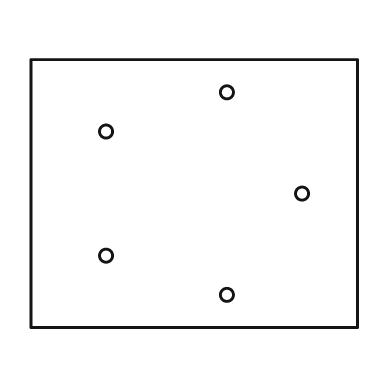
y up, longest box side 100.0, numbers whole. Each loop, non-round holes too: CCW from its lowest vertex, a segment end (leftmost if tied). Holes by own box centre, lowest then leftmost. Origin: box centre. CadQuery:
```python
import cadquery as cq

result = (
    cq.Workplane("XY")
    .moveTo(-50.0, -41.0)
    .lineTo(50.0, -41.0)
    .lineTo(50.0, 41.0)
    .lineTo(-50.0, 41.0)
    .close()
    .moveTo(10.0, -31.0)
    .circle(2.0)
    .moveTo(-27.0, -19.0)
    .circle(2.0)
    .moveTo(33.0, 0.0)
    .circle(2.0)
    .moveTo(-27.0, 19.0)
    .circle(2.0)
    .moveTo(10.0, 31.0)
    .circle(2.0)
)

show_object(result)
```